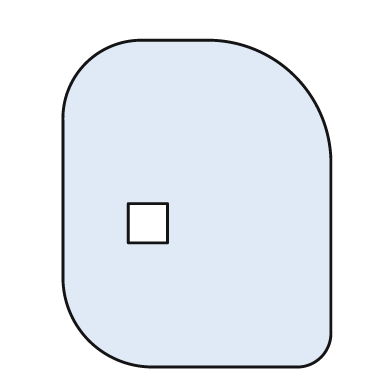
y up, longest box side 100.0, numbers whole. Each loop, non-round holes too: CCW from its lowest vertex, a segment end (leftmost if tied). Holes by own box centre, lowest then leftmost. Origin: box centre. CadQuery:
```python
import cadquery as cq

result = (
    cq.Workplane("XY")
    .moveTo(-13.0, -50.0)
    .lineTo(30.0, -50.0)
    .threePointArc((38.0, -47.0), (41.0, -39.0))
    .lineTo(41.0, 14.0)
    .threePointArc((30.0, 39.0), (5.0, 50.0))
    .lineTo(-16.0, 50.0)
    .threePointArc((-34.0, 43.0), (-41.0, 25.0))
    .lineTo(-41.0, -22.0)
    .threePointArc((-33.0, -42.0), (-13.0, -50.0))
    .close()
    .moveTo(-21.0, -12.0)
    .lineTo(-9.0, -12.0)
    .lineTo(-9.0, 0.0)
    .lineTo(-21.0, 0.0)
    .close()
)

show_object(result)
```